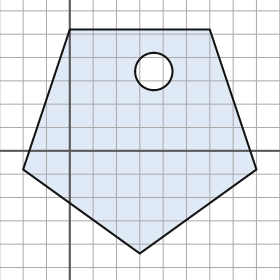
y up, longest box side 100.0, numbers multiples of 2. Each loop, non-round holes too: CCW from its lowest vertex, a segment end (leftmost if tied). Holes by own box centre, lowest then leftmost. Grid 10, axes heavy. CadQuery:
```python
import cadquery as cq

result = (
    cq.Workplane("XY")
    .moveTo(30.0, -44.0)
    .lineTo(80.0, -8.0)
    .lineTo(60.0, 52.0)
    .lineTo(0.0, 52.0)
    .lineTo(-20.0, -8.0)
    .close()
    .moveTo(36.0, 34.0)
    .circle(8.0)
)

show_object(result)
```